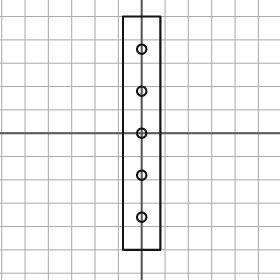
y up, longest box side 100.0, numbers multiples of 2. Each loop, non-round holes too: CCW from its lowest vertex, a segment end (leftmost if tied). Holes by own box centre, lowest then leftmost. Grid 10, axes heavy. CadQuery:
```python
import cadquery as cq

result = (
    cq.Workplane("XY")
    .moveTo(-8.0, -50.0)
    .lineTo(8.0, -50.0)
    .lineTo(8.0, 50.0)
    .lineTo(-8.0, 50.0)
    .close()
    .moveTo(0.0, -36.0)
    .circle(2.0)
    .moveTo(0.0, -18.0)
    .circle(2.0)
    .moveTo(0.0, 0.0)
    .circle(2.0)
    .moveTo(0.0, 18.0)
    .circle(2.0)
    .moveTo(0.0, 36.0)
    .circle(2.0)
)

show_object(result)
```